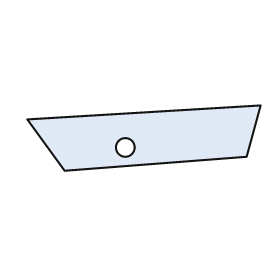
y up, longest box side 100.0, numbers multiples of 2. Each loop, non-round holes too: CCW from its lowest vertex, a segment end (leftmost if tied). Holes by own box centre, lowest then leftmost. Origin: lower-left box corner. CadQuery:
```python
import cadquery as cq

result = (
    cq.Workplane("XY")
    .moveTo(16.0, 0.0)
    .lineTo(94.0, 6.0)
    .lineTo(100.0, 28.0)
    .lineTo(0.0, 22.0)
    .close()
    .moveTo(42.0, 10.0)
    .circle(4.0)
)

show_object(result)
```